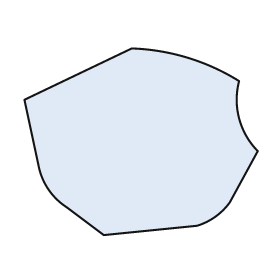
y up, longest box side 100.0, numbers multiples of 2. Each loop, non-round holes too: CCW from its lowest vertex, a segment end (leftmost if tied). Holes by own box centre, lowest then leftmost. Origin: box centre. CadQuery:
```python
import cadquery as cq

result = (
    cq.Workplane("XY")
    .moveTo(-16.0, -40.0)
    .lineTo(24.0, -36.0)
    .threePointArc((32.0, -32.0), (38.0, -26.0))
    .lineTo(50.0, -4.0)
    .threePointArc((42.0, 10.0), (42.0, 26.0))
    .threePointArc((20.0, 36.0), (-4.0, 40.0))
    .lineTo(-50.0, 18.0)
    .lineTo(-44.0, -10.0)
    .threePointArc((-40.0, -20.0), (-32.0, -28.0))
    .close()
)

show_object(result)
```